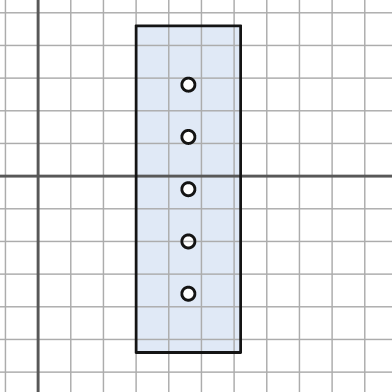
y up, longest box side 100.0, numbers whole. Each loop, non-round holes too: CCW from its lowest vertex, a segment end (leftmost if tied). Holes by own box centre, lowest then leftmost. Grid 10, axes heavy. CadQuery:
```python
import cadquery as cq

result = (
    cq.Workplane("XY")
    .moveTo(30.0, -54.0)
    .lineTo(62.0, -54.0)
    .lineTo(62.0, 46.0)
    .lineTo(30.0, 46.0)
    .close()
    .moveTo(46.0, -36.0)
    .circle(2.0)
    .moveTo(46.0, -20.0)
    .circle(2.0)
    .moveTo(46.0, -4.0)
    .circle(2.0)
    .moveTo(46.0, 12.0)
    .circle(2.0)
    .moveTo(46.0, 28.0)
    .circle(2.0)
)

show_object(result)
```